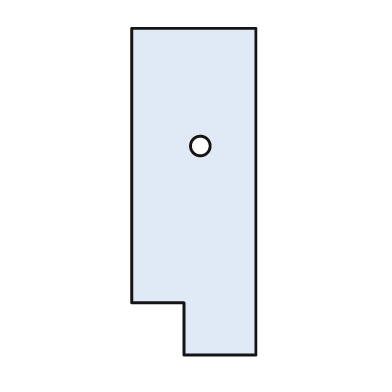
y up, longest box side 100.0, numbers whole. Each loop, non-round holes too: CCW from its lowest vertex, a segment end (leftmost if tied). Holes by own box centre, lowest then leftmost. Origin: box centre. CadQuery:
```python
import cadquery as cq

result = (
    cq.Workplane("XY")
    .moveTo(-3.0, -50.0)
    .lineTo(19.0, -50.0)
    .lineTo(19.0, 50.0)
    .lineTo(-19.0, 50.0)
    .lineTo(-19.0, -34.0)
    .lineTo(-3.0, -34.0)
    .close()
    .moveTo(2.0, 14.0)
    .circle(3.0)
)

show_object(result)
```